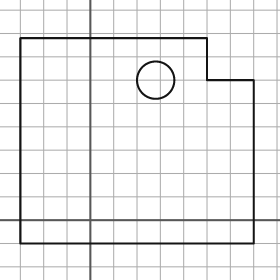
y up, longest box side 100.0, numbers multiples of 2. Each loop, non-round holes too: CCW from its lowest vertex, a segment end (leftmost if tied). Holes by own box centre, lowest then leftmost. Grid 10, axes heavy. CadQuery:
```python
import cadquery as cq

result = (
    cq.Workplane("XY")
    .moveTo(-30.0, -10.0)
    .lineTo(70.0, -10.0)
    .lineTo(70.0, 60.0)
    .lineTo(50.0, 60.0)
    .lineTo(50.0, 78.0)
    .lineTo(-30.0, 78.0)
    .close()
    .moveTo(28.0, 60.0)
    .circle(8.0)
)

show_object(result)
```